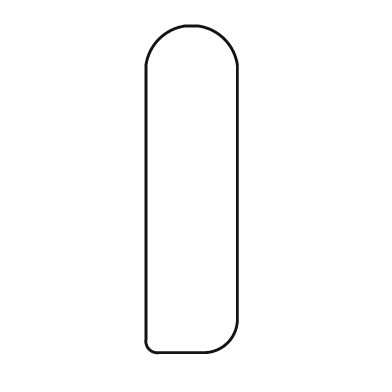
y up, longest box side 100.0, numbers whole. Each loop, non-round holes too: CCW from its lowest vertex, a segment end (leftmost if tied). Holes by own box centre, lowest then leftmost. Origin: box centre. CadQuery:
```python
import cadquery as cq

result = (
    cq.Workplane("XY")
    .moveTo(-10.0, -50.0)
    .lineTo(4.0, -50.0)
    .threePointArc((11.0, -47.0), (14.0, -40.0))
    .lineTo(14.0, 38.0)
    .threePointArc((10.0, 46.0), (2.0, 50.0))
    .lineTo(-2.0, 50.0)
    .threePointArc((-10.0, 46.0), (-14.0, 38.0))
    .lineTo(-14.0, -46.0)
    .threePointArc((-13.0, -49.0), (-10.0, -50.0))
    .close()
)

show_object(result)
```